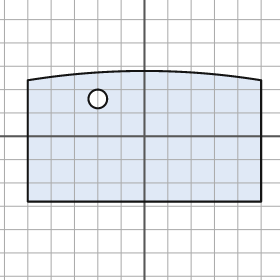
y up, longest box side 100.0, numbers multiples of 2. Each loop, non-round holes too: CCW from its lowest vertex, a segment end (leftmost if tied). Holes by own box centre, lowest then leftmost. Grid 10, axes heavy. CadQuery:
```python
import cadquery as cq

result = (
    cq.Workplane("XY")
    .moveTo(-50.0, -28.0)
    .lineTo(50.0, -28.0)
    .lineTo(50.0, 24.0)
    .threePointArc((0.0, 28.0), (-50.0, 24.0))
    .close()
    .moveTo(-20.0, 16.0)
    .circle(4.0)
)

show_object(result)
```